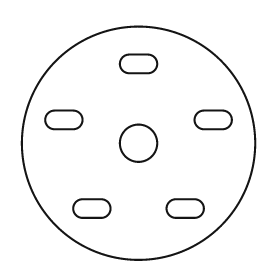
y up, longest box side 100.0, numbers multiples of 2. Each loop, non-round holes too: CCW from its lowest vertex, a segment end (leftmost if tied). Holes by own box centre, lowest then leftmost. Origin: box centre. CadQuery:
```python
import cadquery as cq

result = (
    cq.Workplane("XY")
    .moveTo(0.0, 0.0)
    .circle(50.0)
    .moveTo(-24.0, -32.0)
    .lineTo(-16.0, -32.0)
    .threePointArc((-12.0, -28.0), (-16.0, -24.0))
    .lineTo(-24.0, -24.0)
    .threePointArc((-28.0, -28.0), (-24.0, -32.0))
    .close()
    .moveTo(16.0, -32.0)
    .lineTo(24.0, -32.0)
    .threePointArc((28.0, -28.0), (24.0, -24.0))
    .lineTo(16.0, -24.0)
    .threePointArc((12.0, -28.0), (16.0, -32.0))
    .close()
    .moveTo(0.0, 0.0)
    .circle(8.0)
    .moveTo(-36.0, 6.0)
    .lineTo(-28.0, 6.0)
    .threePointArc((-24.0, 10.0), (-28.0, 14.0))
    .lineTo(-36.0, 14.0)
    .threePointArc((-40.0, 10.0), (-36.0, 6.0))
    .close()
    .moveTo(28.0, 6.0)
    .lineTo(36.0, 6.0)
    .threePointArc((40.0, 10.0), (36.0, 14.0))
    .lineTo(28.0, 14.0)
    .threePointArc((24.0, 10.0), (28.0, 6.0))
    .close()
    .moveTo(-4.0, 30.0)
    .lineTo(4.0, 30.0)
    .threePointArc((8.0, 34.0), (4.0, 38.0))
    .lineTo(-4.0, 38.0)
    .threePointArc((-8.0, 34.0), (-4.0, 30.0))
    .close()
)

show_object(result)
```